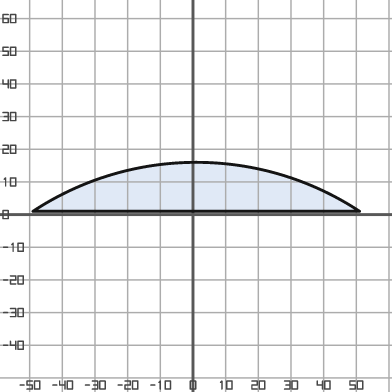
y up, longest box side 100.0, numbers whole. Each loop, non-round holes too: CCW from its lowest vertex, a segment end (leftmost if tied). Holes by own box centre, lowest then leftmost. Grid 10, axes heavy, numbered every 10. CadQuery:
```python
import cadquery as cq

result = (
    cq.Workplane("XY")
    .moveTo(-49.0, 1.0)
    .lineTo(51.0, 1.0)
    .threePointArc((1.0, 16.0), (-49.0, 1.0))
    .close()
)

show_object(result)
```